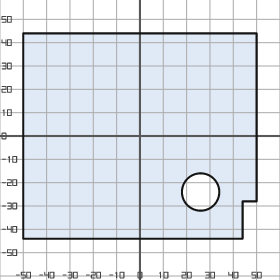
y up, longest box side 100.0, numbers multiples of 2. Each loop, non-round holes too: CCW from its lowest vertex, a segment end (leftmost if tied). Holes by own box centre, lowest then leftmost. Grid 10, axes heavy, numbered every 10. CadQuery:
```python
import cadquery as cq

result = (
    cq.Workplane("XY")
    .moveTo(-50.0, -44.0)
    .lineTo(44.0, -44.0)
    .lineTo(44.0, -28.0)
    .lineTo(50.0, -28.0)
    .lineTo(50.0, 44.0)
    .lineTo(-50.0, 44.0)
    .close()
    .moveTo(26.0, -24.0)
    .circle(8.0)
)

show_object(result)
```